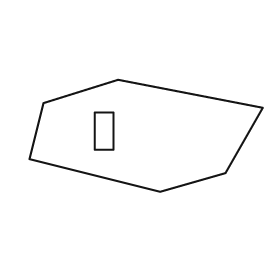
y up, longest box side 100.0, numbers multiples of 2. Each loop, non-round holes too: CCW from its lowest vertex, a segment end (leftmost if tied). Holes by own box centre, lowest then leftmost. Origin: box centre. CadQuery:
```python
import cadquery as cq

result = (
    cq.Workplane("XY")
    .moveTo(6.0, -24.0)
    .lineTo(34.0, -16.0)
    .lineTo(50.0, 12.0)
    .lineTo(-12.0, 24.0)
    .lineTo(-44.0, 14.0)
    .lineTo(-50.0, -10.0)
    .close()
    .moveTo(-22.0, -6.0)
    .lineTo(-14.0, -6.0)
    .lineTo(-14.0, 10.0)
    .lineTo(-22.0, 10.0)
    .close()
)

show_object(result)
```